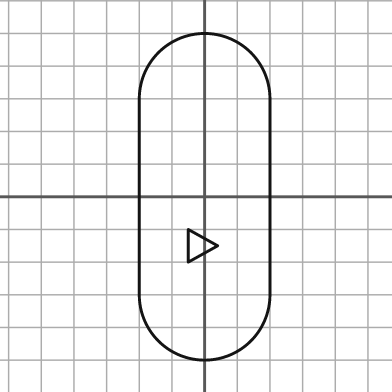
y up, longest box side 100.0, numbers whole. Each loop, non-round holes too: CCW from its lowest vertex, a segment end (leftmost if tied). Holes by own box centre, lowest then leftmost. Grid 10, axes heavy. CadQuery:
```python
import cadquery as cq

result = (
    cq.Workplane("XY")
    .moveTo(-20.0, -30.0)
    .threePointArc((0.0, -50.0), (20.0, -30.0))
    .lineTo(20.0, 30.0)
    .threePointArc((0.0, 50.0), (-20.0, 30.0))
    .close()
    .moveTo(-5.0, -20.0)
    .lineTo(4.0, -15.0)
    .lineTo(-5.0, -10.0)
    .close()
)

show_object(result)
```